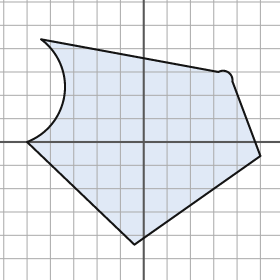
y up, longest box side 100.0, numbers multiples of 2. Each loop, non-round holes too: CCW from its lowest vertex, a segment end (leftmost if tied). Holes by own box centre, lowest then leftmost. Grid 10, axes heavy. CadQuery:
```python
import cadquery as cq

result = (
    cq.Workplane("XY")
    .moveTo(-4.0, -44.0)
    .lineTo(50.0, -6.0)
    .lineTo(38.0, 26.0)
    .threePointArc((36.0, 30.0), (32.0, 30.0))
    .lineTo(-44.0, 44.0)
    .threePointArc((-34.0, 20.0), (-50.0, 0.0))
    .close()
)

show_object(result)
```